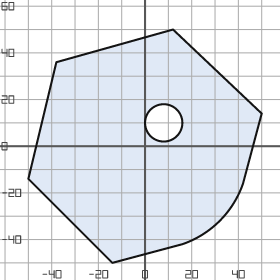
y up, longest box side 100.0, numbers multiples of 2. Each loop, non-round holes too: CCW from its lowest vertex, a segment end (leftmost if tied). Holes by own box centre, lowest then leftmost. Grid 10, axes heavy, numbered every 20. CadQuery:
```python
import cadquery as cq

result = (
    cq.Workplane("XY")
    .moveTo(-14.0, -50.0)
    .lineTo(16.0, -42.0)
    .threePointArc((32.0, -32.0), (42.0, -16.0))
    .lineTo(50.0, 14.0)
    .lineTo(12.0, 50.0)
    .lineTo(-38.0, 36.0)
    .lineTo(-50.0, -14.0)
    .close()
    .moveTo(8.0, 10.0)
    .circle(8.0)
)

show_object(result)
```